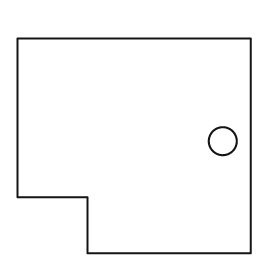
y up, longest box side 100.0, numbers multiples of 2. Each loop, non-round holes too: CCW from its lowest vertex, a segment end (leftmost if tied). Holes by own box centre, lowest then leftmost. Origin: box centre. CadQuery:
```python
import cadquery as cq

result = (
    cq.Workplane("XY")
    .moveTo(-20.0, -46.0)
    .lineTo(50.0, -46.0)
    .lineTo(50.0, 46.0)
    .lineTo(-50.0, 46.0)
    .lineTo(-50.0, -22.0)
    .lineTo(-20.0, -22.0)
    .close()
    .moveTo(38.0, 2.0)
    .circle(6.0)
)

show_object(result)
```